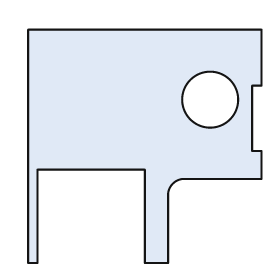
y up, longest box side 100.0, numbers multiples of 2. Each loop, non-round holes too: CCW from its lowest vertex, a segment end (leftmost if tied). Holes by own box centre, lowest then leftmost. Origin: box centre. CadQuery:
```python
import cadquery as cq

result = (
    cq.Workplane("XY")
    .moveTo(-50.0, -50.0)
    .lineTo(-46.0, -50.0)
    .lineTo(-46.0, -10.0)
    .lineTo(0.0, -10.0)
    .lineTo(0.0, -50.0)
    .lineTo(10.0, -50.0)
    .lineTo(10.0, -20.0)
    .threePointArc((12.0, -16.0), (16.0, -14.0))
    .lineTo(50.0, -14.0)
    .lineTo(50.0, -2.0)
    .lineTo(46.0, -2.0)
    .lineTo(46.0, 26.0)
    .lineTo(50.0, 26.0)
    .lineTo(50.0, 50.0)
    .lineTo(-50.0, 50.0)
    .close()
    .moveTo(28.0, 20.0)
    .circle(12.0)
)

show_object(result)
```